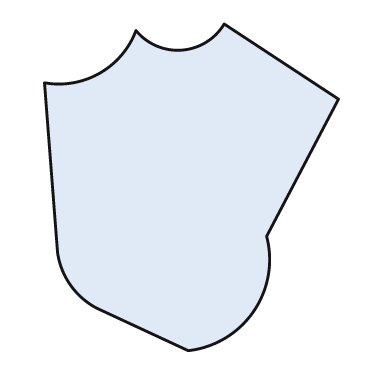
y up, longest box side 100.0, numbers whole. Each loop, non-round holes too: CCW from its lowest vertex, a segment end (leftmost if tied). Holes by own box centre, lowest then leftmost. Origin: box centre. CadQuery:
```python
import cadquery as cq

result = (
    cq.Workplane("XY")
    .moveTo(-1.0, -50.0)
    .threePointArc((19.0, -38.0), (23.0, -15.0))
    .lineTo(45.0, 27.0)
    .lineTo(10.0, 50.0)
    .threePointArc((-3.0, 42.0), (-17.0, 48.0))
    .threePointArc((-28.0, 35.0), (-45.0, 32.0))
    .lineTo(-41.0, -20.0)
    .threePointArc((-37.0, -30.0), (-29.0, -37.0))
    .close()
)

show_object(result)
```